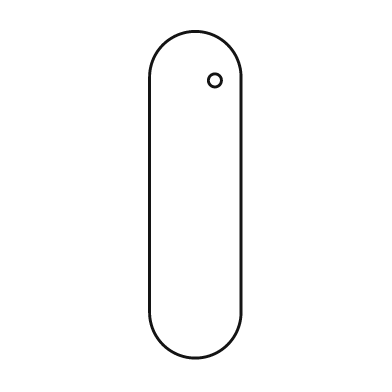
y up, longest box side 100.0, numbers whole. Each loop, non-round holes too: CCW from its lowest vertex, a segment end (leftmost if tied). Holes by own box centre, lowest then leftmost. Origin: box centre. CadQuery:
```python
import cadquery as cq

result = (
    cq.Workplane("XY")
    .moveTo(-14.0, -36.0)
    .threePointArc((0.0, -50.0), (14.0, -36.0))
    .lineTo(14.0, 36.0)
    .threePointArc((0.0, 50.0), (-14.0, 36.0))
    .close()
    .moveTo(6.0, 35.0)
    .circle(2.0)
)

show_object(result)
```